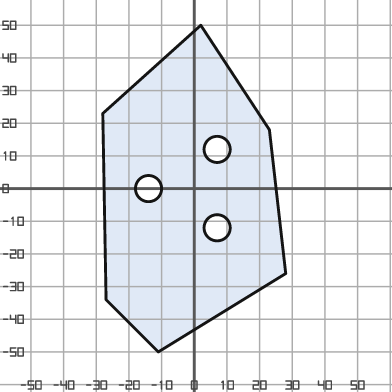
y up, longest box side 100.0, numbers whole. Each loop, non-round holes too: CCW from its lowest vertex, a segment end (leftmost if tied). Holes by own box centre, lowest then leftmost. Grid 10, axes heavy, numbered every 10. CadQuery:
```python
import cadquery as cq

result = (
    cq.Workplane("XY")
    .moveTo(-11.0, -50.0)
    .lineTo(28.0, -26.0)
    .lineTo(23.0, 18.0)
    .lineTo(2.0, 50.0)
    .lineTo(-28.0, 23.0)
    .lineTo(-27.0, -34.0)
    .close()
    .moveTo(7.0, -12.0)
    .circle(4.0)
    .moveTo(-14.0, 0.0)
    .circle(4.0)
    .moveTo(7.0, 12.0)
    .circle(4.0)
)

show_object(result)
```